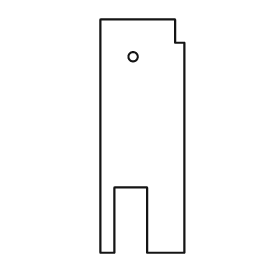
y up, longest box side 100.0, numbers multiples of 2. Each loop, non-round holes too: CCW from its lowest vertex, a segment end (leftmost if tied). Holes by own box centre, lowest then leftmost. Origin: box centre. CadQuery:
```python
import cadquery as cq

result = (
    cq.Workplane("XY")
    .moveTo(-18.0, -50.0)
    .lineTo(-12.0, -50.0)
    .lineTo(-12.0, -22.0)
    .lineTo(2.0, -22.0)
    .lineTo(2.0, -50.0)
    .lineTo(18.0, -50.0)
    .lineTo(18.0, 40.0)
    .lineTo(14.0, 40.0)
    .lineTo(14.0, 50.0)
    .lineTo(-18.0, 50.0)
    .close()
    .moveTo(-4.0, 34.0)
    .circle(2.0)
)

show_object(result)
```